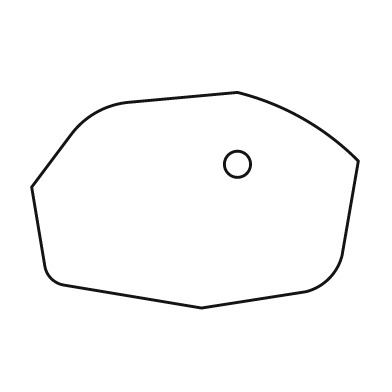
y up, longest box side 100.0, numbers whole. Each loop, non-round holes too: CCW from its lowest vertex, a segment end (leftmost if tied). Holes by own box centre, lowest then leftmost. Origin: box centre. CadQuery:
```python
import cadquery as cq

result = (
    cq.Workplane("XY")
    .moveTo(2.0, -33.0)
    .lineTo(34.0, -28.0)
    .threePointArc((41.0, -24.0), (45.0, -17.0))
    .lineTo(50.0, 12.0)
    .threePointArc((33.0, 25.0), (13.0, 33.0))
    .lineTo(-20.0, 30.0)
    .threePointArc((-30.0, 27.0), (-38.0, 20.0))
    .lineTo(-50.0, 4.0)
    .lineTo(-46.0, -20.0)
    .threePointArc((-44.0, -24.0), (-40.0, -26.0))
    .close()
    .moveTo(13.0, 11.0)
    .circle(4.0)
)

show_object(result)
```